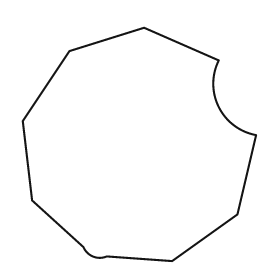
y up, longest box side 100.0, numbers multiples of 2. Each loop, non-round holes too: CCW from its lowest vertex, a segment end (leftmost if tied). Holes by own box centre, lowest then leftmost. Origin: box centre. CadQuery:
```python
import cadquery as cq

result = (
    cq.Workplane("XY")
    .moveTo(14.0, -50.0)
    .lineTo(42.0, -30.0)
    .lineTo(50.0, 4.0)
    .threePointArc((34.0, 16.0), (34.0, 36.0))
    .lineTo(2.0, 50.0)
    .lineTo(-30.0, 40.0)
    .lineTo(-50.0, 10.0)
    .lineTo(-46.0, -24.0)
    .lineTo(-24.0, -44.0)
    .threePointArc((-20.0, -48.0), (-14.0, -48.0))
    .close()
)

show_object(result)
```